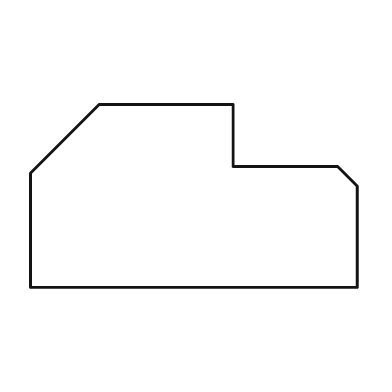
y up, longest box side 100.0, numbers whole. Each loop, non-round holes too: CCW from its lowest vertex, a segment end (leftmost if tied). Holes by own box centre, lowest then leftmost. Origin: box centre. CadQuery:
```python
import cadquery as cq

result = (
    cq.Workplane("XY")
    .moveTo(-50.0, -28.0)
    .lineTo(50.0, -28.0)
    .lineTo(50.0, 3.0)
    .lineTo(44.0, 9.0)
    .lineTo(12.0, 9.0)
    .lineTo(12.0, 28.0)
    .lineTo(-29.0, 28.0)
    .lineTo(-50.0, 7.0)
    .close()
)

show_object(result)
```